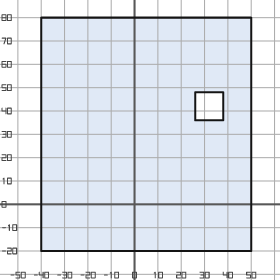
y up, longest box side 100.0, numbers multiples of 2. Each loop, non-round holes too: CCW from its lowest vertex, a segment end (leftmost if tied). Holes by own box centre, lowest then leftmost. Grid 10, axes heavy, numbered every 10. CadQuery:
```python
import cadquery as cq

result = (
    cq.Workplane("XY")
    .moveTo(-40.0, -20.0)
    .lineTo(50.0, -20.0)
    .lineTo(50.0, 80.0)
    .lineTo(-40.0, 80.0)
    .close()
    .moveTo(26.0, 36.0)
    .lineTo(38.0, 36.0)
    .lineTo(38.0, 48.0)
    .lineTo(26.0, 48.0)
    .close()
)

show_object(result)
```